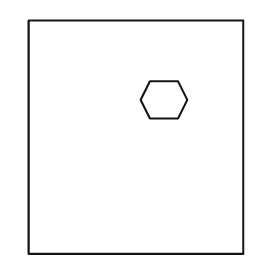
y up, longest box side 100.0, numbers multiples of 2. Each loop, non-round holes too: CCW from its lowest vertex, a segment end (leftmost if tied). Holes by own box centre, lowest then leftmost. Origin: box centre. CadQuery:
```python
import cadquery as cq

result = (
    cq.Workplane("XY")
    .moveTo(-46.0, -50.0)
    .lineTo(46.0, -50.0)
    .lineTo(46.0, 50.0)
    .lineTo(-46.0, 50.0)
    .close()
    .moveTo(6.0, 8.0)
    .lineTo(18.0, 8.0)
    .lineTo(22.0, 16.0)
    .lineTo(18.0, 24.0)
    .lineTo(6.0, 24.0)
    .lineTo(2.0, 16.0)
    .close()
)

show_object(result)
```